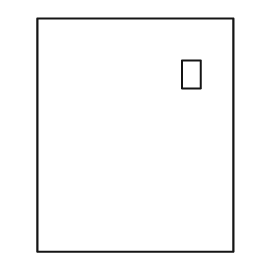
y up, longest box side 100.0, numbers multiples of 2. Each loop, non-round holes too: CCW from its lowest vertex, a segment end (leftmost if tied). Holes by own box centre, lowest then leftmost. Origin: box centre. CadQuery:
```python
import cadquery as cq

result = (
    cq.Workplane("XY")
    .moveTo(-42.0, -50.0)
    .lineTo(42.0, -50.0)
    .lineTo(42.0, 50.0)
    .lineTo(-42.0, 50.0)
    .close()
    .moveTo(20.0, 20.0)
    .lineTo(28.0, 20.0)
    .lineTo(28.0, 32.0)
    .lineTo(20.0, 32.0)
    .close()
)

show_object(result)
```